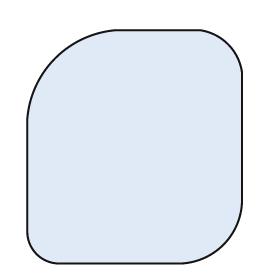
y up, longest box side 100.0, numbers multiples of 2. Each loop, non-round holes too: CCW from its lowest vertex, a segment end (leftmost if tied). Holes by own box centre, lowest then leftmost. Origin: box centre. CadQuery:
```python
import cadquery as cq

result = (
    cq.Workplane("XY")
    .moveTo(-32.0, -50.0)
    .lineTo(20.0, -50.0)
    .threePointArc((38.0, -42.0), (46.0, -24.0))
    .lineTo(46.0, 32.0)
    .threePointArc((40.0, 44.0), (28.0, 50.0))
    .lineTo(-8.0, 50.0)
    .threePointArc((-34.0, 38.0), (-46.0, 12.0))
    .lineTo(-46.0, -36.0)
    .threePointArc((-42.0, -46.0), (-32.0, -50.0))
    .close()
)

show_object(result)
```